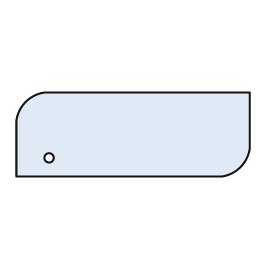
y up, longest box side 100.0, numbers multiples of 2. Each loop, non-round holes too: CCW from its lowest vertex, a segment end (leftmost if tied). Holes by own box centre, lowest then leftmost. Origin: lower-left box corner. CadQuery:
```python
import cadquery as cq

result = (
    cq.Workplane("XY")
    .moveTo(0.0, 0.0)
    .lineTo(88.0, 0.0)
    .threePointArc((96.0, 4.0), (100.0, 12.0))
    .lineTo(100.0, 36.0)
    .lineTo(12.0, 36.0)
    .threePointArc((4.0, 32.0), (0.0, 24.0))
    .close()
    .moveTo(14.0, 8.0)
    .circle(2.0)
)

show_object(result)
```